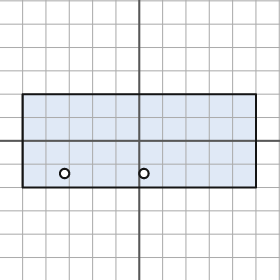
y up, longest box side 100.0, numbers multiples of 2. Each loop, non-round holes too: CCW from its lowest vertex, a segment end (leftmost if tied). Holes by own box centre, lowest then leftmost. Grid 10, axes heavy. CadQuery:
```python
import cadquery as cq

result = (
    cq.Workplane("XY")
    .moveTo(-50.0, -20.0)
    .lineTo(50.0, -20.0)
    .lineTo(50.0, 20.0)
    .lineTo(-50.0, 20.0)
    .close()
    .moveTo(-32.0, -14.0)
    .circle(2.0)
    .moveTo(2.0, -14.0)
    .circle(2.0)
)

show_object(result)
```